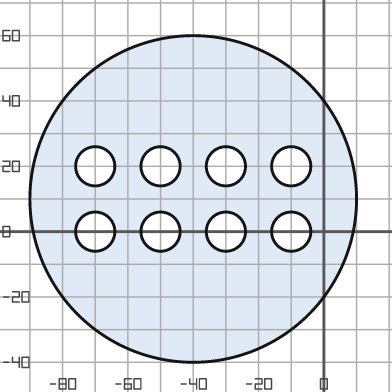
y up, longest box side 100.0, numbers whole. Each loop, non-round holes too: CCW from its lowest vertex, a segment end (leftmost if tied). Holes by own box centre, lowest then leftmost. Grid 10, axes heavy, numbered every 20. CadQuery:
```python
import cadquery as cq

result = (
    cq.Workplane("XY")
    .moveTo(-40.0, 10.0)
    .circle(50.0)
    .moveTo(-70.0, 0.0)
    .circle(6.0)
    .moveTo(-50.0, 0.0)
    .circle(6.0)
    .moveTo(-30.0, 0.0)
    .circle(6.0)
    .moveTo(-10.0, 0.0)
    .circle(6.0)
    .moveTo(-70.0, 20.0)
    .circle(6.0)
    .moveTo(-50.0, 20.0)
    .circle(6.0)
    .moveTo(-30.0, 20.0)
    .circle(6.0)
    .moveTo(-10.0, 20.0)
    .circle(6.0)
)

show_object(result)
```